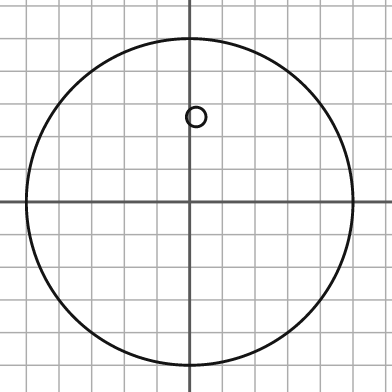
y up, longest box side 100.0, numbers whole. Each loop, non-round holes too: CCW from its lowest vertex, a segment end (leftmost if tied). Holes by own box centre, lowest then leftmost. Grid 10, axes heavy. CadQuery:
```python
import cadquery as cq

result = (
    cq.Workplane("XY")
    .moveTo(0.0, 0.0)
    .circle(50.0)
    .moveTo(2.0, 26.0)
    .circle(3.0)
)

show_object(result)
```